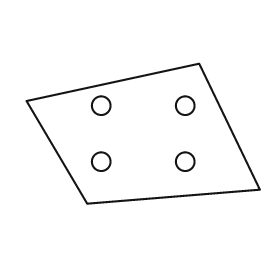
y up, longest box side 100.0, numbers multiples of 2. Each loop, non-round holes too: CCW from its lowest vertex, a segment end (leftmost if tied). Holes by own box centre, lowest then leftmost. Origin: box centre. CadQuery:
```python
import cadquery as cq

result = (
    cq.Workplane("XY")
    .moveTo(-24.0, -30.0)
    .lineTo(50.0, -24.0)
    .lineTo(24.0, 30.0)
    .lineTo(-50.0, 14.0)
    .close()
    .moveTo(-18.0, -12.0)
    .circle(4.0)
    .moveTo(18.0, -12.0)
    .circle(4.0)
    .moveTo(-18.0, 12.0)
    .circle(4.0)
    .moveTo(18.0, 12.0)
    .circle(4.0)
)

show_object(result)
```